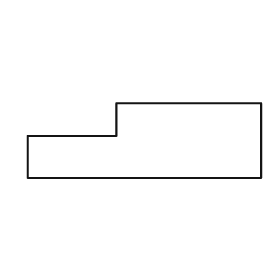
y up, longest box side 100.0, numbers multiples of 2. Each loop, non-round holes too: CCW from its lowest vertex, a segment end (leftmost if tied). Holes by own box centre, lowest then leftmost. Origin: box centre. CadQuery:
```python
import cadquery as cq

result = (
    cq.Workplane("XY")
    .moveTo(-50.0, -16.0)
    .lineTo(50.0, -16.0)
    .lineTo(50.0, 16.0)
    .lineTo(-12.0, 16.0)
    .lineTo(-12.0, 2.0)
    .lineTo(-50.0, 2.0)
    .close()
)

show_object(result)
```